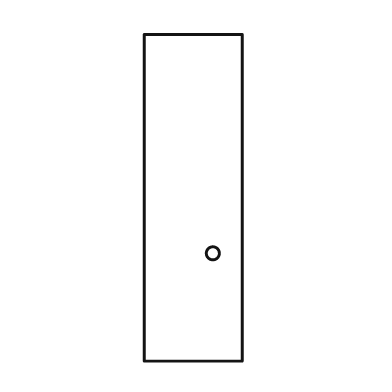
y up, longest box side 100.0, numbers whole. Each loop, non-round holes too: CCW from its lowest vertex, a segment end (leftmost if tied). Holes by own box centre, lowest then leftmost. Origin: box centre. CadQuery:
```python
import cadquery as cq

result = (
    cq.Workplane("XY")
    .moveTo(-15.0, -50.0)
    .lineTo(15.0, -50.0)
    .lineTo(15.0, 50.0)
    .lineTo(-15.0, 50.0)
    .close()
    .moveTo(6.0, -17.0)
    .circle(2.0)
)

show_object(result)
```